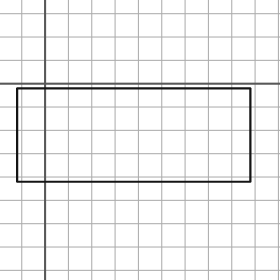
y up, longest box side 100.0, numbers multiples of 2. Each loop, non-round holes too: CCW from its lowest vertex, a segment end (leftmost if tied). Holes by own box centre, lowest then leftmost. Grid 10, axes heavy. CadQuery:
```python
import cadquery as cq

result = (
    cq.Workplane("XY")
    .moveTo(-12.0, -42.0)
    .lineTo(88.0, -42.0)
    .lineTo(88.0, -2.0)
    .lineTo(-12.0, -2.0)
    .close()
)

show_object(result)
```